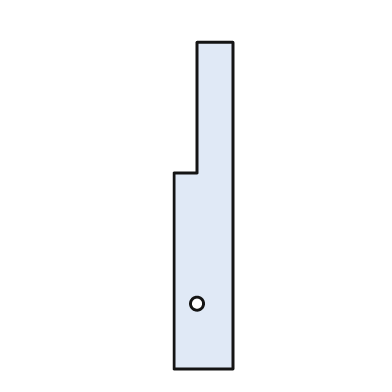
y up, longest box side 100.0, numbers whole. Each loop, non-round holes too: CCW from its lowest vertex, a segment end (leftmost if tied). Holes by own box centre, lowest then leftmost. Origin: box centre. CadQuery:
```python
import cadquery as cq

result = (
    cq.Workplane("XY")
    .moveTo(-9.0, -50.0)
    .lineTo(9.0, -50.0)
    .lineTo(9.0, 50.0)
    .lineTo(-2.0, 50.0)
    .lineTo(-2.0, 10.0)
    .lineTo(-9.0, 10.0)
    .close()
    .moveTo(-2.0, -30.0)
    .circle(2.0)
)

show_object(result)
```